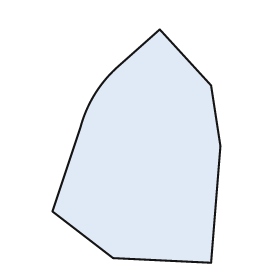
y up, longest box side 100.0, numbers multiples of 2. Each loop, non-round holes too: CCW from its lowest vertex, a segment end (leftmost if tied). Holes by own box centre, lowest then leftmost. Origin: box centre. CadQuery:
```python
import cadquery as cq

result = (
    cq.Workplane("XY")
    .moveTo(32.0, -50.0)
    .lineTo(36.0, 0.0)
    .lineTo(32.0, 26.0)
    .lineTo(10.0, 50.0)
    .lineTo(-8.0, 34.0)
    .threePointArc((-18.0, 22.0), (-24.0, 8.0))
    .lineTo(-36.0, -28.0)
    .lineTo(-10.0, -48.0)
    .close()
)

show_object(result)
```